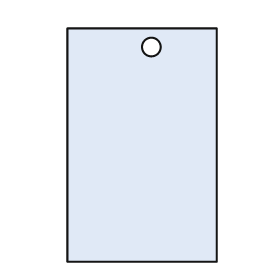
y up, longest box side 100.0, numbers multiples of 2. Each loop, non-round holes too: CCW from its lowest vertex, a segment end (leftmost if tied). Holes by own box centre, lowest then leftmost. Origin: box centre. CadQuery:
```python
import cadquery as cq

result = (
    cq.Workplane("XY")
    .moveTo(-32.0, -50.0)
    .lineTo(32.0, -50.0)
    .lineTo(32.0, 50.0)
    .lineTo(-32.0, 50.0)
    .close()
    .moveTo(4.0, 42.0)
    .circle(4.0)
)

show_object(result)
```